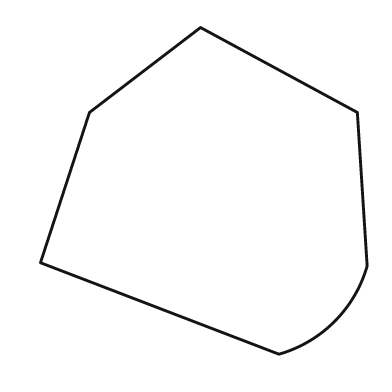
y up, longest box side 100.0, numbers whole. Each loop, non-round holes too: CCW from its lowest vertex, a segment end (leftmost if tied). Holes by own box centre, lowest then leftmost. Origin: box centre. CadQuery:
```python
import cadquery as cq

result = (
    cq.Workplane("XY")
    .moveTo(23.0, -50.0)
    .threePointArc((40.0, -40.0), (50.0, -23.0))
    .lineTo(47.0, 24.0)
    .lineTo(-1.0, 50.0)
    .lineTo(-35.0, 24.0)
    .lineTo(-50.0, -22.0)
    .close()
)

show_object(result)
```